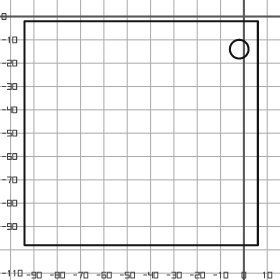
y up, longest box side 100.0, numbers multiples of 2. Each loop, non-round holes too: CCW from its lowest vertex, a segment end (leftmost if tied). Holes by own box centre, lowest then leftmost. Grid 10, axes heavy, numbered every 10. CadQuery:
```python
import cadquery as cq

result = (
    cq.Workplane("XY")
    .moveTo(-94.0, -98.0)
    .lineTo(6.0, -98.0)
    .lineTo(6.0, -2.0)
    .lineTo(-94.0, -2.0)
    .close()
    .moveTo(-2.0, -14.0)
    .circle(4.0)
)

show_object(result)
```